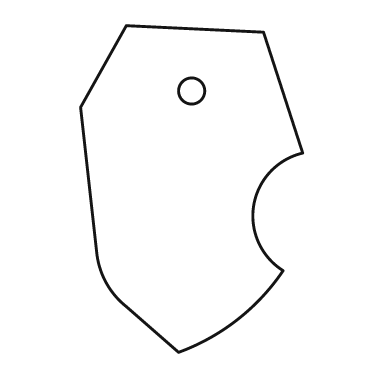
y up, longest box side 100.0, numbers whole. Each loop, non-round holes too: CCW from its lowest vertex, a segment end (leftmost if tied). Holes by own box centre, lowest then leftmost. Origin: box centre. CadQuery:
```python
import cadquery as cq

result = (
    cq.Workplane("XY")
    .moveTo(-4.0, -50.0)
    .threePointArc((14.0, -40.0), (28.0, -25.0))
    .threePointArc((19.0, -5.0), (34.0, 11.0))
    .lineTo(22.0, 48.0)
    .lineTo(-20.0, 50.0)
    .lineTo(-34.0, 25.0)
    .lineTo(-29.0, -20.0)
    .threePointArc((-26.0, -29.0), (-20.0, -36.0))
    .close()
    .moveTo(0.0, 30.0)
    .circle(4.0)
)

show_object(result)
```